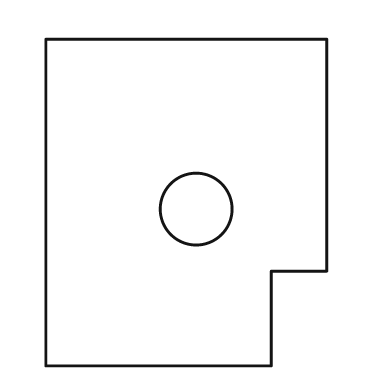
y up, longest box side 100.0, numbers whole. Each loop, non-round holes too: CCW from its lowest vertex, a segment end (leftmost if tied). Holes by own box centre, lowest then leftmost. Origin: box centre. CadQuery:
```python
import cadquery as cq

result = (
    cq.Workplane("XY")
    .moveTo(-43.0, -50.0)
    .lineTo(26.0, -50.0)
    .lineTo(26.0, -21.0)
    .lineTo(43.0, -21.0)
    .lineTo(43.0, 50.0)
    .lineTo(-43.0, 50.0)
    .close()
    .moveTo(3.0, -2.0)
    .circle(11.0)
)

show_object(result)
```